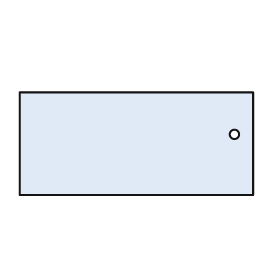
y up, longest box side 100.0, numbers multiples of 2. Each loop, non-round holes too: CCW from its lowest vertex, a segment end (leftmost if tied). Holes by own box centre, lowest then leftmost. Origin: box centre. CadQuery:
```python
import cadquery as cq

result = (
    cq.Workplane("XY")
    .moveTo(-50.0, -22.0)
    .lineTo(50.0, -22.0)
    .lineTo(50.0, 22.0)
    .lineTo(-50.0, 22.0)
    .close()
    .moveTo(42.0, 4.0)
    .circle(2.0)
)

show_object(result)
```